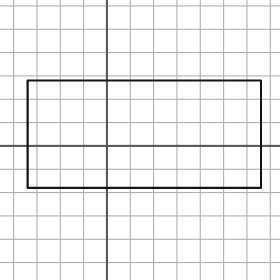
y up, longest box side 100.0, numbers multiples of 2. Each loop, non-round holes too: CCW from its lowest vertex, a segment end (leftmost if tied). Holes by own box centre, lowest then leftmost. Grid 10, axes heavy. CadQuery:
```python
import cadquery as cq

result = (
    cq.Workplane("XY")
    .moveTo(-34.0, -18.0)
    .lineTo(66.0, -18.0)
    .lineTo(66.0, 28.0)
    .lineTo(-34.0, 28.0)
    .close()
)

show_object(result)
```